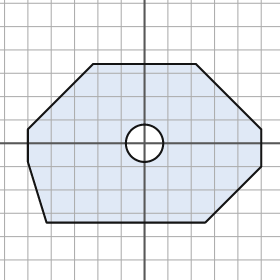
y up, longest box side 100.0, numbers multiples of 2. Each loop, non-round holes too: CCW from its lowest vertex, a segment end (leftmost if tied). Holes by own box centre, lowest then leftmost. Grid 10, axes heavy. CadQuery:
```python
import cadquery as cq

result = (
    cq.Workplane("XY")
    .moveTo(-42.0, -34.0)
    .lineTo(26.0, -34.0)
    .lineTo(50.0, -10.0)
    .lineTo(50.0, 6.0)
    .lineTo(22.0, 34.0)
    .lineTo(-22.0, 34.0)
    .lineTo(-50.0, 6.0)
    .lineTo(-50.0, -8.0)
    .close()
    .moveTo(0.0, 0.0)
    .circle(8.0)
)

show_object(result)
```